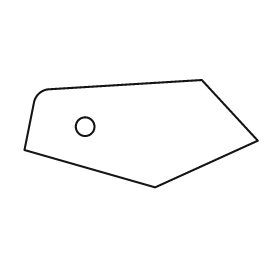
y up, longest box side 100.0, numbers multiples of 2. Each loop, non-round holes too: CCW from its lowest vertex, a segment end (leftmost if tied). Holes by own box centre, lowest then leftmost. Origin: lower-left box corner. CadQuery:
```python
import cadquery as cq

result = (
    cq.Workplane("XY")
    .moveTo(56.0, 0.0)
    .lineTo(100.0, 20.0)
    .lineTo(76.0, 46.0)
    .lineTo(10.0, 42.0)
    .threePointArc((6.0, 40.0), (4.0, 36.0))
    .lineTo(0.0, 16.0)
    .close()
    .moveTo(26.0, 26.0)
    .circle(4.0)
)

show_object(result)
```